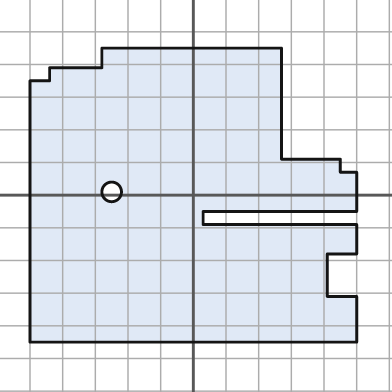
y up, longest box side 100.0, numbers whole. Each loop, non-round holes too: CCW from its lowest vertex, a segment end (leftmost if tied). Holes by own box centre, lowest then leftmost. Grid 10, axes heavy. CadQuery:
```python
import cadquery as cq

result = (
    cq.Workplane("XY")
    .moveTo(-50.0, -45.0)
    .lineTo(50.0, -45.0)
    .lineTo(50.0, -31.0)
    .lineTo(41.0, -31.0)
    .lineTo(41.0, -18.0)
    .lineTo(50.0, -18.0)
    .lineTo(50.0, -9.0)
    .lineTo(3.0, -9.0)
    .lineTo(3.0, -5.0)
    .lineTo(50.0, -5.0)
    .lineTo(50.0, 7.0)
    .lineTo(45.0, 7.0)
    .lineTo(45.0, 11.0)
    .lineTo(27.0, 11.0)
    .lineTo(27.0, 45.0)
    .lineTo(-28.0, 45.0)
    .lineTo(-28.0, 39.0)
    .lineTo(-44.0, 39.0)
    .lineTo(-44.0, 35.0)
    .lineTo(-50.0, 35.0)
    .close()
    .moveTo(-25.0, 1.0)
    .circle(3.0)
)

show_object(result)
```